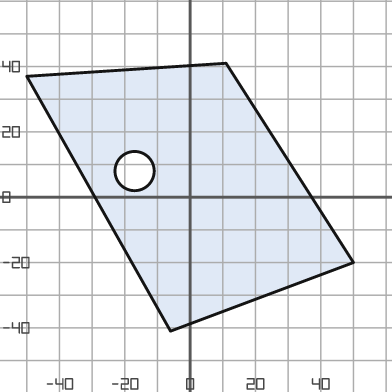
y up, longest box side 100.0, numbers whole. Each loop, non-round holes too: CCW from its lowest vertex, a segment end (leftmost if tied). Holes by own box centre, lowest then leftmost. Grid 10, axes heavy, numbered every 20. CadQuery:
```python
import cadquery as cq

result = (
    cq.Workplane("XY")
    .moveTo(-6.0, -41.0)
    .lineTo(50.0, -20.0)
    .lineTo(11.0, 41.0)
    .lineTo(-50.0, 37.0)
    .close()
    .moveTo(-17.0, 8.0)
    .circle(6.0)
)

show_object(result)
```